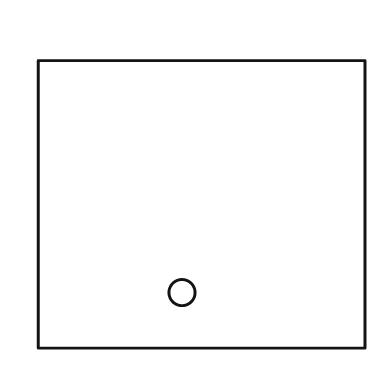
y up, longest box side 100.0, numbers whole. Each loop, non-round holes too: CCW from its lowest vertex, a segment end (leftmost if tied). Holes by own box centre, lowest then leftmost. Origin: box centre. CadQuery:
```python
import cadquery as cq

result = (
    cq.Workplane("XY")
    .moveTo(-50.0, -44.0)
    .lineTo(50.0, -44.0)
    .lineTo(50.0, 44.0)
    .lineTo(-50.0, 44.0)
    .close()
    .moveTo(-6.0, -27.0)
    .circle(4.0)
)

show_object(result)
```